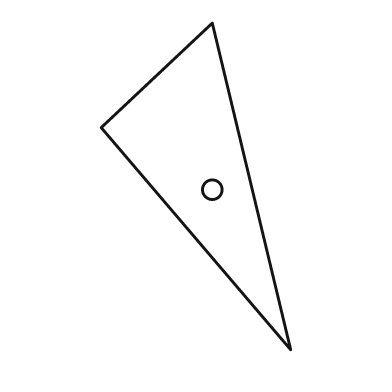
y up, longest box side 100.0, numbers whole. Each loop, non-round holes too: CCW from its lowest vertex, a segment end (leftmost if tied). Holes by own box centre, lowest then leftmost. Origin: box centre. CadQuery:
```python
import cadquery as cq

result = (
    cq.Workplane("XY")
    .moveTo(29.0, -50.0)
    .lineTo(5.0, 50.0)
    .lineTo(-29.0, 18.0)
    .close()
    .moveTo(5.0, -1.0)
    .circle(3.0)
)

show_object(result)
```